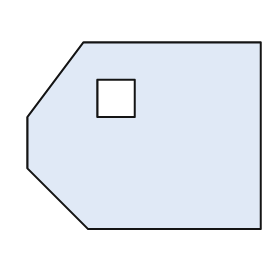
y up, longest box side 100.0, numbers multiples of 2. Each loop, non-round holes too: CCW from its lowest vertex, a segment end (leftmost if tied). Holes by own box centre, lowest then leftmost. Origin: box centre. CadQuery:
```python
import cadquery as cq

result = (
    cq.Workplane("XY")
    .moveTo(-24.0, -40.0)
    .lineTo(50.0, -40.0)
    .lineTo(50.0, 40.0)
    .lineTo(-26.0, 40.0)
    .lineTo(-50.0, 8.0)
    .lineTo(-50.0, -14.0)
    .close()
    .moveTo(-20.0, 8.0)
    .lineTo(-4.0, 8.0)
    .lineTo(-4.0, 24.0)
    .lineTo(-20.0, 24.0)
    .close()
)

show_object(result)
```